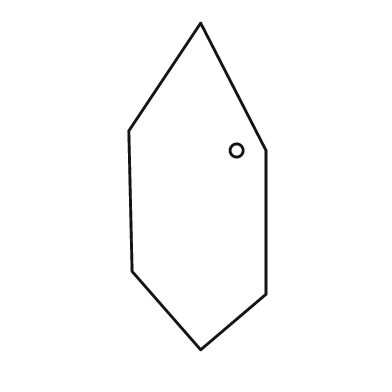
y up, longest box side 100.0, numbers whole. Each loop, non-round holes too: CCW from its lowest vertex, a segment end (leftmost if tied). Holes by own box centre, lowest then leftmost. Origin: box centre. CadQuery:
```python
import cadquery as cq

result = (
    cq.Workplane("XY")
    .moveTo(1.0, -50.0)
    .lineTo(21.0, -33.0)
    .lineTo(21.0, 11.0)
    .lineTo(1.0, 50.0)
    .lineTo(-21.0, 17.0)
    .lineTo(-20.0, -26.0)
    .close()
    .moveTo(12.0, 11.0)
    .circle(2.0)
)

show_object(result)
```